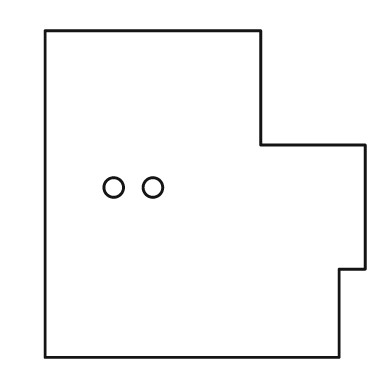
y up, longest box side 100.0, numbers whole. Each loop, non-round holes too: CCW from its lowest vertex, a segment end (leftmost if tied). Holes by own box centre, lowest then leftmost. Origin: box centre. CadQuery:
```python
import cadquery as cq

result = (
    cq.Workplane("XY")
    .moveTo(-49.0, -50.0)
    .lineTo(41.0, -50.0)
    .lineTo(41.0, -23.0)
    .lineTo(49.0, -23.0)
    .lineTo(49.0, 15.0)
    .lineTo(17.0, 15.0)
    .lineTo(17.0, 50.0)
    .lineTo(-49.0, 50.0)
    .close()
    .moveTo(-28.0, 2.0)
    .circle(3.0)
    .moveTo(-16.0, 2.0)
    .circle(3.0)
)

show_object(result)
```